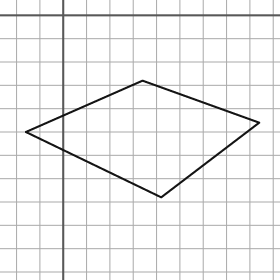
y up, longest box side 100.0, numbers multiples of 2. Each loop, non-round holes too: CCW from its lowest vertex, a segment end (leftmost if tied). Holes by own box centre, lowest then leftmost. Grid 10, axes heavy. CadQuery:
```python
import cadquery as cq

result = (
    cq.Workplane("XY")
    .moveTo(42.0, -78.0)
    .lineTo(84.0, -46.0)
    .lineTo(34.0, -28.0)
    .lineTo(-16.0, -50.0)
    .close()
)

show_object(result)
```